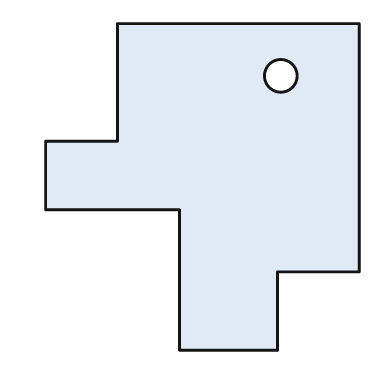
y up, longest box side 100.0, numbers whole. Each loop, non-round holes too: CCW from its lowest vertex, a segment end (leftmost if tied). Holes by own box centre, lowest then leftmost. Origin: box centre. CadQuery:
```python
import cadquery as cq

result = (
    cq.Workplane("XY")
    .moveTo(-7.0, -50.0)
    .lineTo(23.0, -50.0)
    .lineTo(23.0, -26.0)
    .lineTo(48.0, -26.0)
    .lineTo(48.0, 50.0)
    .lineTo(-26.0, 50.0)
    .lineTo(-26.0, 14.0)
    .lineTo(-48.0, 14.0)
    .lineTo(-48.0, -7.0)
    .lineTo(-7.0, -7.0)
    .close()
    .moveTo(24.0, 34.0)
    .circle(5.0)
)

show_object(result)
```